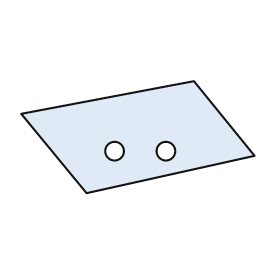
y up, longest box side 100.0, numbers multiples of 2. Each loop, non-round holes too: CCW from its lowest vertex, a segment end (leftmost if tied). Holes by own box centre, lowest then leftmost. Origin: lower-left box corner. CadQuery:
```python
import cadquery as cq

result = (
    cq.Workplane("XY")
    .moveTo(28.0, 0.0)
    .lineTo(100.0, 16.0)
    .lineTo(74.0, 48.0)
    .lineTo(0.0, 34.0)
    .close()
    .moveTo(40.0, 18.0)
    .circle(4.0)
    .moveTo(62.0, 18.0)
    .circle(4.0)
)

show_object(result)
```